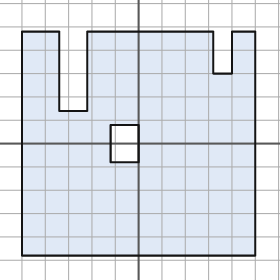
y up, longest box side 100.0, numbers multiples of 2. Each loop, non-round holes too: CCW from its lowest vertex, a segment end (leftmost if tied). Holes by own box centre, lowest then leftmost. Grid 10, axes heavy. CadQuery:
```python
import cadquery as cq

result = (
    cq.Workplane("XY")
    .moveTo(-50.0, -48.0)
    .lineTo(50.0, -48.0)
    .lineTo(50.0, 48.0)
    .lineTo(40.0, 48.0)
    .lineTo(40.0, 30.0)
    .lineTo(32.0, 30.0)
    .lineTo(32.0, 48.0)
    .lineTo(-22.0, 48.0)
    .lineTo(-22.0, 14.0)
    .lineTo(-34.0, 14.0)
    .lineTo(-34.0, 48.0)
    .lineTo(-50.0, 48.0)
    .close()
    .moveTo(-12.0, -8.0)
    .lineTo(0.0, -8.0)
    .lineTo(0.0, 8.0)
    .lineTo(-12.0, 8.0)
    .close()
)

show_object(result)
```